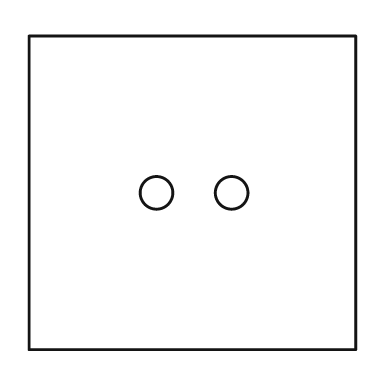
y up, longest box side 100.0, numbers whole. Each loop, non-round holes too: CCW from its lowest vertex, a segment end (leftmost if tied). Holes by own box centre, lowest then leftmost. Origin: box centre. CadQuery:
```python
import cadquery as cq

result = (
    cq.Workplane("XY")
    .moveTo(-50.0, -48.0)
    .lineTo(50.0, -48.0)
    .lineTo(50.0, 48.0)
    .lineTo(-50.0, 48.0)
    .close()
    .moveTo(-11.0, 0.0)
    .circle(5.0)
    .moveTo(12.0, 0.0)
    .circle(5.0)
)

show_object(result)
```